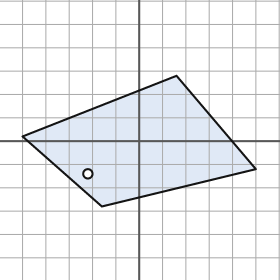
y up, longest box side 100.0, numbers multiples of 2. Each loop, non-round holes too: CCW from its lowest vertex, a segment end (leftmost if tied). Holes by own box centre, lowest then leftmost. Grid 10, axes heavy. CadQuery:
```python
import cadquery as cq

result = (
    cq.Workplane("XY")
    .moveTo(-16.0, -28.0)
    .lineTo(50.0, -12.0)
    .lineTo(16.0, 28.0)
    .lineTo(-50.0, 2.0)
    .close()
    .moveTo(-22.0, -14.0)
    .circle(2.0)
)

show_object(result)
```